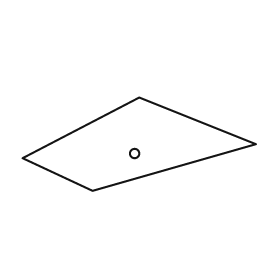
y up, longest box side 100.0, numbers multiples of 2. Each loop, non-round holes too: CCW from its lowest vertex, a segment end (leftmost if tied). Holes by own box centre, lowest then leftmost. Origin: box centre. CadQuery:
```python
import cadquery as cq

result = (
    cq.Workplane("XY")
    .moveTo(-20.0, -20.0)
    .lineTo(50.0, 0.0)
    .lineTo(0.0, 20.0)
    .lineTo(-50.0, -6.0)
    .close()
    .moveTo(-2.0, -4.0)
    .circle(2.0)
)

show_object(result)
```